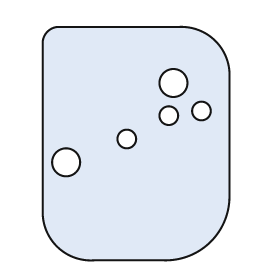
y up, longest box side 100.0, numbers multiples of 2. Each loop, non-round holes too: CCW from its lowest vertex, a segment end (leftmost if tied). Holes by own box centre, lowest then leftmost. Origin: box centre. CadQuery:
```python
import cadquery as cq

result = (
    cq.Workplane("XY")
    .moveTo(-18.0, -50.0)
    .lineTo(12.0, -50.0)
    .threePointArc((32.0, -42.0), (40.0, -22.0))
    .lineTo(40.0, 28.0)
    .threePointArc((34.0, 44.0), (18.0, 50.0))
    .lineTo(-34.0, 50.0)
    .threePointArc((-38.0, 48.0), (-40.0, 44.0))
    .lineTo(-40.0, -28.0)
    .threePointArc((-34.0, -44.0), (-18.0, -50.0))
    .close()
    .moveTo(-30.0, -8.0)
    .circle(6.0)
    .moveTo(-4.0, 2.0)
    .circle(4.0)
    .moveTo(14.0, 12.0)
    .circle(4.0)
    .moveTo(28.0, 14.0)
    .circle(4.0)
    .moveTo(16.0, 26.0)
    .circle(6.0)
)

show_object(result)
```